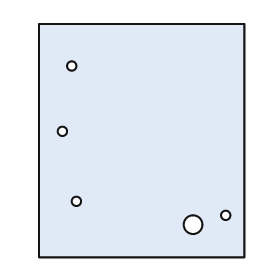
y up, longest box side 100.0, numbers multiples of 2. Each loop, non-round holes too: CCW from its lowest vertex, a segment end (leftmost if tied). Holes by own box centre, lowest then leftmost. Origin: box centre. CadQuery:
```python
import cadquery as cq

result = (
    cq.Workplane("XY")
    .moveTo(-44.0, -50.0)
    .lineTo(44.0, -50.0)
    .lineTo(44.0, 50.0)
    .lineTo(-44.0, 50.0)
    .close()
    .moveTo(22.0, -36.0)
    .circle(4.0)
    .moveTo(36.0, -32.0)
    .circle(2.0)
    .moveTo(-28.0, -26.0)
    .circle(2.0)
    .moveTo(-34.0, 4.0)
    .circle(2.0)
    .moveTo(-30.0, 32.0)
    .circle(2.0)
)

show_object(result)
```